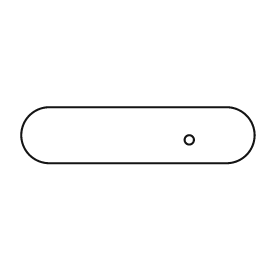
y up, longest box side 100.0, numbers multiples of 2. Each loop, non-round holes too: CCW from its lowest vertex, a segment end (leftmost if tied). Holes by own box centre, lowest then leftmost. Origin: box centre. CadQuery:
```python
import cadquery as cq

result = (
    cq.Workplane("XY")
    .moveTo(-38.0, -12.0)
    .lineTo(38.0, -12.0)
    .threePointArc((50.0, 0.0), (38.0, 12.0))
    .lineTo(-38.0, 12.0)
    .threePointArc((-50.0, 0.0), (-38.0, -12.0))
    .close()
    .moveTo(22.0, -2.0)
    .circle(2.0)
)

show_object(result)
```